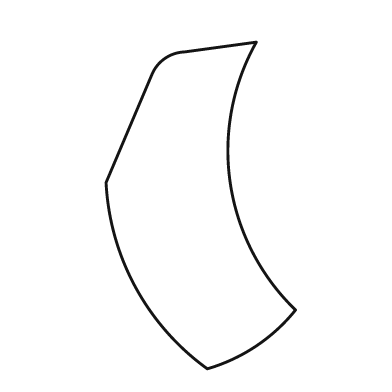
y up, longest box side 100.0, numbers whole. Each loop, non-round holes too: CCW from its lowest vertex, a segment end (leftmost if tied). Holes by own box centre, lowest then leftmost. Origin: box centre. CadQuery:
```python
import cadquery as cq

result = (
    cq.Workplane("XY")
    .moveTo(2.0, -50.0)
    .threePointArc((17.0, -43.0), (29.0, -32.0))
    .threePointArc((9.0, 7.0), (17.0, 50.0))
    .lineTo(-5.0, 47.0)
    .threePointArc((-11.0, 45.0), (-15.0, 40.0))
    .lineTo(-29.0, 7.0)
    .threePointArc((-20.0, -25.0), (2.0, -50.0))
    .close()
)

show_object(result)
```